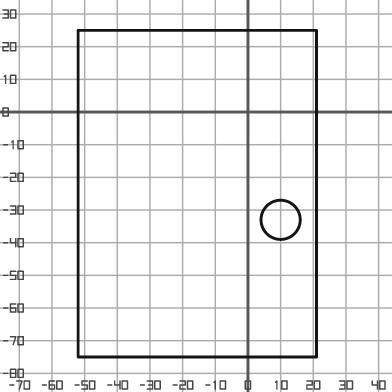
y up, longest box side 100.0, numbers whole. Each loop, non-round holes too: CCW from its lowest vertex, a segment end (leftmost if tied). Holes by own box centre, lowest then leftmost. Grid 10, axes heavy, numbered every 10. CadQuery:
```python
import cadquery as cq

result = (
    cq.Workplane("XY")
    .moveTo(-52.0, -75.0)
    .lineTo(21.0, -75.0)
    .lineTo(21.0, 25.0)
    .lineTo(-52.0, 25.0)
    .close()
    .moveTo(10.0, -33.0)
    .circle(6.0)
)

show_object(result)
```